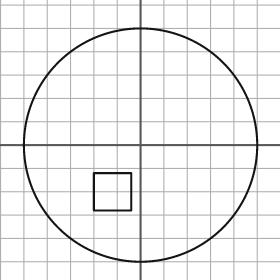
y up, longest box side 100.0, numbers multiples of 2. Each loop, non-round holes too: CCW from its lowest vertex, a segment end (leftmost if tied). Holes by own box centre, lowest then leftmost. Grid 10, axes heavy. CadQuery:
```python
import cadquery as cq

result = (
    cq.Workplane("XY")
    .moveTo(0.0, 0.0)
    .circle(50.0)
    .moveTo(-20.0, -28.0)
    .lineTo(-4.0, -28.0)
    .lineTo(-4.0, -12.0)
    .lineTo(-20.0, -12.0)
    .close()
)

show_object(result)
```